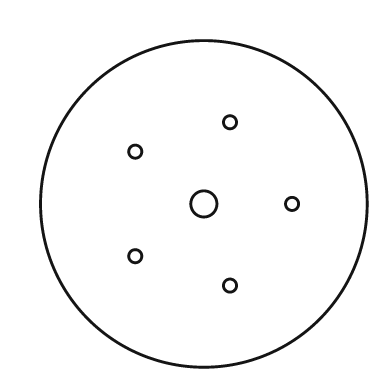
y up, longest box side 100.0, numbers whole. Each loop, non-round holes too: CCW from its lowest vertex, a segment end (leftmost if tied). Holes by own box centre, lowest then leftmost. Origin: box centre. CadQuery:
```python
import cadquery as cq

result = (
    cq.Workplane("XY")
    .moveTo(0.0, 0.0)
    .circle(50.0)
    .moveTo(8.0, -25.0)
    .circle(2.0)
    .moveTo(-21.0, -16.0)
    .circle(2.0)
    .moveTo(0.0, 0.0)
    .circle(4.0)
    .moveTo(27.0, 0.0)
    .circle(2.0)
    .moveTo(-21.0, 16.0)
    .circle(2.0)
    .moveTo(8.0, 25.0)
    .circle(2.0)
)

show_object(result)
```